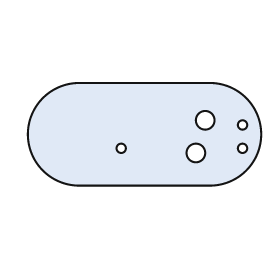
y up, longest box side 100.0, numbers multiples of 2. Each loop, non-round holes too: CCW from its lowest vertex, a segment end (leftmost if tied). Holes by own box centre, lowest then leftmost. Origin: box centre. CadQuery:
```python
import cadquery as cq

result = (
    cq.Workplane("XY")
    .moveTo(-28.0, -22.0)
    .lineTo(28.0, -22.0)
    .threePointArc((50.0, 0.0), (28.0, 22.0))
    .lineTo(-28.0, 22.0)
    .threePointArc((-50.0, 0.0), (-28.0, -22.0))
    .close()
    .moveTo(22.0, -8.0)
    .circle(4.0)
    .moveTo(-10.0, -6.0)
    .circle(2.0)
    .moveTo(42.0, -6.0)
    .circle(2.0)
    .moveTo(42.0, 4.0)
    .circle(2.0)
    .moveTo(26.0, 6.0)
    .circle(4.0)
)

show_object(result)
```